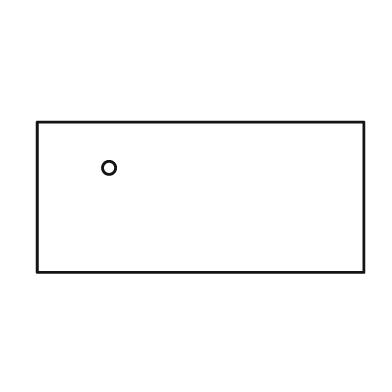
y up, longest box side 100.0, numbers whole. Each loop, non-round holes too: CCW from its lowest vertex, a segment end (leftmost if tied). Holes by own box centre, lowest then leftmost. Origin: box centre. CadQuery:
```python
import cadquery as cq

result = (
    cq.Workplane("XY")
    .moveTo(-50.0, -23.0)
    .lineTo(50.0, -23.0)
    .lineTo(50.0, 23.0)
    .lineTo(-50.0, 23.0)
    .close()
    .moveTo(-28.0, 9.0)
    .circle(2.0)
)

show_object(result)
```